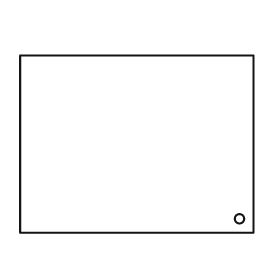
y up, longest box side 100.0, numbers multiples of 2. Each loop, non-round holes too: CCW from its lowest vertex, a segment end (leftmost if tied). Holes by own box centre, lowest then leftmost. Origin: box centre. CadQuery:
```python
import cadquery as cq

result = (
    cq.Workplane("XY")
    .moveTo(-50.0, -38.0)
    .lineTo(50.0, -38.0)
    .lineTo(50.0, 38.0)
    .lineTo(-50.0, 38.0)
    .close()
    .moveTo(44.0, -32.0)
    .circle(2.0)
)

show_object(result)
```